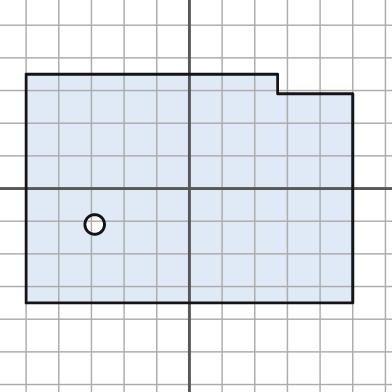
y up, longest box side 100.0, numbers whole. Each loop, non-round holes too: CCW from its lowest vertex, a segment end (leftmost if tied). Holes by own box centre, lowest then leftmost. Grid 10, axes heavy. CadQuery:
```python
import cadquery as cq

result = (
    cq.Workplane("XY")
    .moveTo(-50.0, -35.0)
    .lineTo(50.0, -35.0)
    .lineTo(50.0, 29.0)
    .lineTo(27.0, 29.0)
    .lineTo(27.0, 35.0)
    .lineTo(-50.0, 35.0)
    .close()
    .moveTo(-29.0, -11.0)
    .circle(3.0)
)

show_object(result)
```